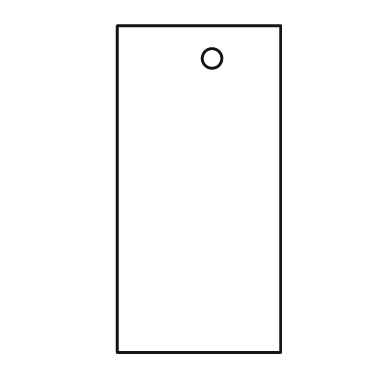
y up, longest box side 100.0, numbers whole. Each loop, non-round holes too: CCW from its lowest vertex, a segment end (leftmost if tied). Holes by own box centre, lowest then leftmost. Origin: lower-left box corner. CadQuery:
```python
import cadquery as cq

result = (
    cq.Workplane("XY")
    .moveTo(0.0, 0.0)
    .lineTo(50.0, 0.0)
    .lineTo(50.0, 100.0)
    .lineTo(0.0, 100.0)
    .close()
    .moveTo(29.0, 90.0)
    .circle(3.0)
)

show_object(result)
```